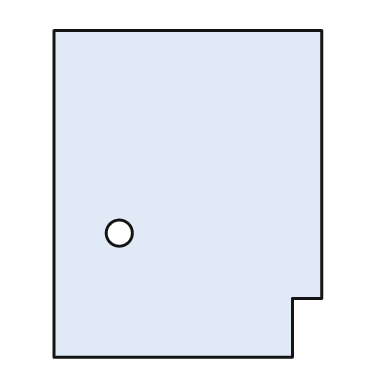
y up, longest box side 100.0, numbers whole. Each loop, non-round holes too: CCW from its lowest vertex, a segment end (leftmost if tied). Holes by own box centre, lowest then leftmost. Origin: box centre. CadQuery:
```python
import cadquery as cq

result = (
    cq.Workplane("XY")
    .moveTo(-41.0, -50.0)
    .lineTo(32.0, -50.0)
    .lineTo(32.0, -32.0)
    .lineTo(41.0, -32.0)
    .lineTo(41.0, 50.0)
    .lineTo(-41.0, 50.0)
    .close()
    .moveTo(-21.0, -12.0)
    .circle(4.0)
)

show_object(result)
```